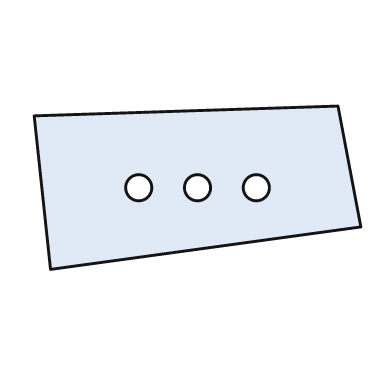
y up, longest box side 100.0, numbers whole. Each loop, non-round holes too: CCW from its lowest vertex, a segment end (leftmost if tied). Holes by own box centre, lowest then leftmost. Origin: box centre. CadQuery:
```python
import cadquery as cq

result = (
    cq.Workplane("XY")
    .moveTo(-45.0, -25.0)
    .lineTo(50.0, -12.0)
    .lineTo(43.0, 25.0)
    .lineTo(-50.0, 22.0)
    .close()
    .moveTo(-18.0, 0.0)
    .circle(4.0)
    .moveTo(0.0, 0.0)
    .circle(4.0)
    .moveTo(18.0, 0.0)
    .circle(4.0)
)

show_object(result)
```